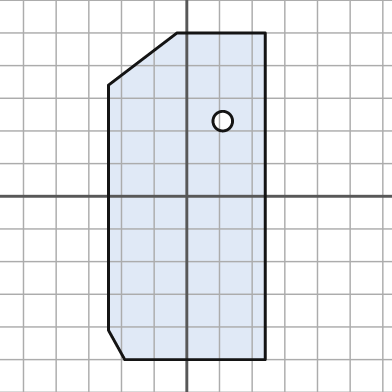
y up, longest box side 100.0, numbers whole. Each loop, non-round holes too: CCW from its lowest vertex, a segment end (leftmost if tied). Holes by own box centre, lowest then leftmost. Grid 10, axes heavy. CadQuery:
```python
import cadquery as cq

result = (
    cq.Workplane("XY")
    .moveTo(-19.0, -50.0)
    .lineTo(24.0, -50.0)
    .lineTo(24.0, 50.0)
    .lineTo(-3.0, 50.0)
    .lineTo(-24.0, 34.0)
    .lineTo(-24.0, -41.0)
    .close()
    .moveTo(11.0, 23.0)
    .circle(3.0)
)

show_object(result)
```